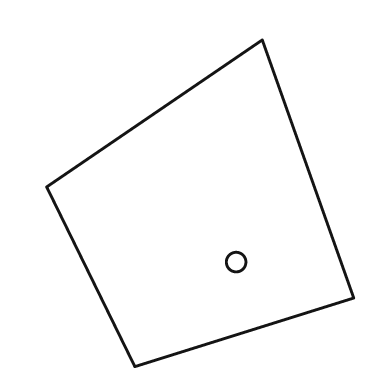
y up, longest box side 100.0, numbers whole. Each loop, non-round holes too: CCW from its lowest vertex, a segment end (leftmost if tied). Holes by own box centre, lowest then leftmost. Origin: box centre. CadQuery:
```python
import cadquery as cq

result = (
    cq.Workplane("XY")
    .moveTo(-20.0, -50.0)
    .lineTo(47.0, -29.0)
    .lineTo(19.0, 50.0)
    .lineTo(-47.0, 5.0)
    .close()
    .moveTo(11.0, -18.0)
    .circle(3.0)
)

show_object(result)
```